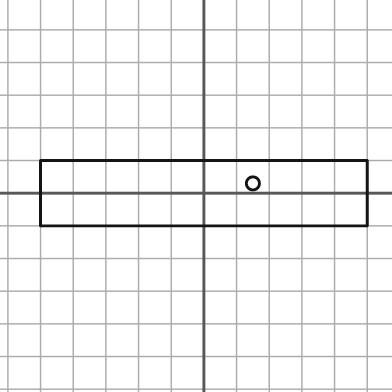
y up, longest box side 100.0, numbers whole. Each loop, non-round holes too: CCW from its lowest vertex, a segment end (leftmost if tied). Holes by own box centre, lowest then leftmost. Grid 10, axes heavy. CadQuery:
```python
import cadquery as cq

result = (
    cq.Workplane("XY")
    .moveTo(-50.0, -10.0)
    .lineTo(50.0, -10.0)
    .lineTo(50.0, 10.0)
    .lineTo(-50.0, 10.0)
    .close()
    .moveTo(15.0, 3.0)
    .circle(2.0)
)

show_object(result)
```